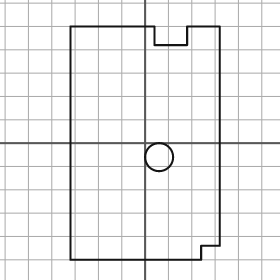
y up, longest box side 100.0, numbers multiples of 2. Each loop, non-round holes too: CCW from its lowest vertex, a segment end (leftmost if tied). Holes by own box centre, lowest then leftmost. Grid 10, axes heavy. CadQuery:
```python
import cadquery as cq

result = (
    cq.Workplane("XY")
    .moveTo(-32.0, -50.0)
    .lineTo(24.0, -50.0)
    .lineTo(24.0, -44.0)
    .lineTo(32.0, -44.0)
    .lineTo(32.0, 50.0)
    .lineTo(18.0, 50.0)
    .lineTo(18.0, 42.0)
    .lineTo(4.0, 42.0)
    .lineTo(4.0, 50.0)
    .lineTo(-32.0, 50.0)
    .close()
    .moveTo(6.0, -6.0)
    .circle(6.0)
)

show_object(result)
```